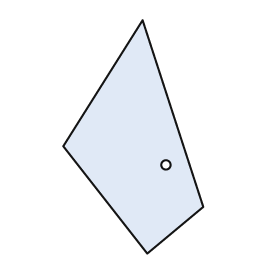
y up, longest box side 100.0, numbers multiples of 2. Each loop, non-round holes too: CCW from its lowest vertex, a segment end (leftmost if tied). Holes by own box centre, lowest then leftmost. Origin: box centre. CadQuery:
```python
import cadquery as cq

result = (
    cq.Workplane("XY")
    .moveTo(6.0, -50.0)
    .lineTo(30.0, -30.0)
    .lineTo(4.0, 50.0)
    .lineTo(-30.0, -4.0)
    .close()
    .moveTo(14.0, -12.0)
    .circle(2.0)
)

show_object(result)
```